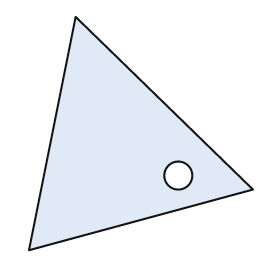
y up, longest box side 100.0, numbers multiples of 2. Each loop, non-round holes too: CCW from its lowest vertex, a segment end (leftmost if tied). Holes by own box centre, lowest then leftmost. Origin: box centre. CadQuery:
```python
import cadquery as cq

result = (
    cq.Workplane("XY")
    .moveTo(-48.0, -50.0)
    .lineTo(48.0, -24.0)
    .lineTo(-28.0, 50.0)
    .close()
    .moveTo(16.0, -18.0)
    .circle(6.0)
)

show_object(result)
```